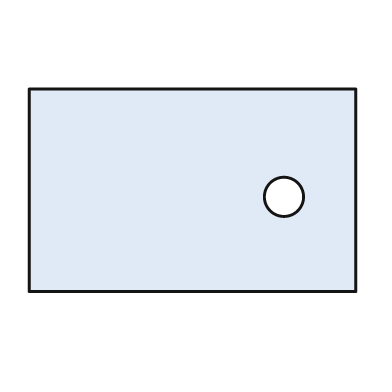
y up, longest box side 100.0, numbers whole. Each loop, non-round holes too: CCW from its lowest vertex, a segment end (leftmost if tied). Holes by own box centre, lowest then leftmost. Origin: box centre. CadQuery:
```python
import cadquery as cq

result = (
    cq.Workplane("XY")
    .moveTo(-50.0, -31.0)
    .lineTo(50.0, -31.0)
    .lineTo(50.0, 31.0)
    .lineTo(-50.0, 31.0)
    .close()
    .moveTo(28.0, -2.0)
    .circle(6.0)
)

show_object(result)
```